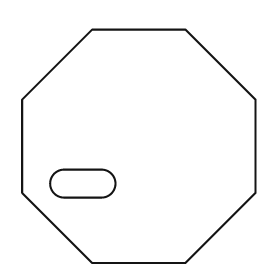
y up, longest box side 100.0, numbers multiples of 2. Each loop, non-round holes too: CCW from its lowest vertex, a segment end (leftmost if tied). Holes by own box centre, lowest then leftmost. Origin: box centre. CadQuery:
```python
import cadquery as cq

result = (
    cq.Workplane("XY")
    .moveTo(-20.0, -50.0)
    .lineTo(20.0, -50.0)
    .lineTo(50.0, -20.0)
    .lineTo(50.0, 20.0)
    .lineTo(20.0, 50.0)
    .lineTo(-20.0, 50.0)
    .lineTo(-50.0, 20.0)
    .lineTo(-50.0, -20.0)
    .close()
    .moveTo(-32.0, -22.0)
    .lineTo(-16.0, -22.0)
    .threePointArc((-10.0, -16.0), (-16.0, -10.0))
    .lineTo(-32.0, -10.0)
    .threePointArc((-38.0, -16.0), (-32.0, -22.0))
    .close()
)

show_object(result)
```